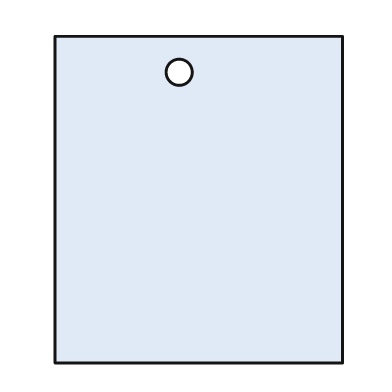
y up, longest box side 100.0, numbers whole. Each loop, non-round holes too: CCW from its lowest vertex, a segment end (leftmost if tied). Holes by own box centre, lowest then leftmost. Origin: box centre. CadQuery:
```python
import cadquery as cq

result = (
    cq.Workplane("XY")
    .moveTo(-44.0, -50.0)
    .lineTo(44.0, -50.0)
    .lineTo(44.0, 50.0)
    .lineTo(-44.0, 50.0)
    .close()
    .moveTo(-6.0, 39.0)
    .circle(4.0)
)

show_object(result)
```